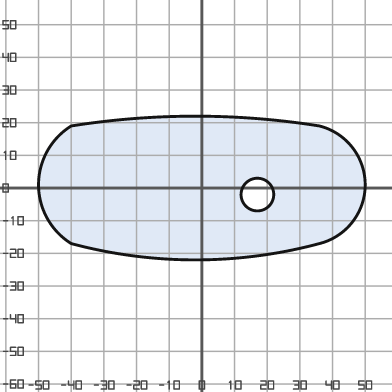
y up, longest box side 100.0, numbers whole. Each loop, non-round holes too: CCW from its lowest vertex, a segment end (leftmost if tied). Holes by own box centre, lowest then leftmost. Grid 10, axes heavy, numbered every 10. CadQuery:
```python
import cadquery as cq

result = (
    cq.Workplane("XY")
    .moveTo(-40.0, -17.0)
    .threePointArc((-2.0, -22.0), (36.0, -17.0))
    .threePointArc((50.0, 1.0), (36.0, 19.0))
    .threePointArc((-2.0, 22.0), (-40.0, 19.0))
    .threePointArc((-50.0, 1.0), (-40.0, -17.0))
    .close()
    .moveTo(17.0, -2.0)
    .circle(5.0)
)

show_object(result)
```